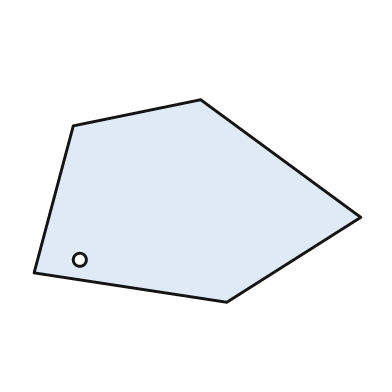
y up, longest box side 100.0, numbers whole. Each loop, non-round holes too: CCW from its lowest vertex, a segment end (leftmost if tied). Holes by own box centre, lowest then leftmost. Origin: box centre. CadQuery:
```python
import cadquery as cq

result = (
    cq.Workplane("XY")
    .moveTo(9.0, -31.0)
    .lineTo(50.0, -5.0)
    .lineTo(1.0, 31.0)
    .lineTo(-38.0, 23.0)
    .lineTo(-50.0, -22.0)
    .close()
    .moveTo(-36.0, -18.0)
    .circle(2.0)
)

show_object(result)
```